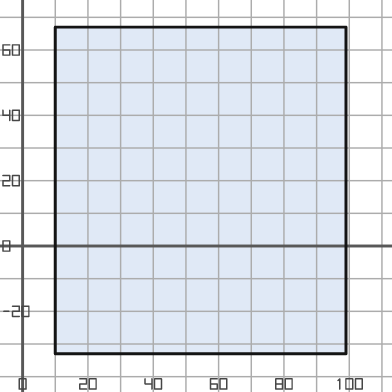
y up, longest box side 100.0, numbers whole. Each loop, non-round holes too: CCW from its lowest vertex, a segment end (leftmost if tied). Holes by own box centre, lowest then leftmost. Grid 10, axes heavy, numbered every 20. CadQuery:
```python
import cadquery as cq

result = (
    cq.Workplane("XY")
    .moveTo(10.0, -33.0)
    .lineTo(99.0, -33.0)
    .lineTo(99.0, 67.0)
    .lineTo(10.0, 67.0)
    .close()
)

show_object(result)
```